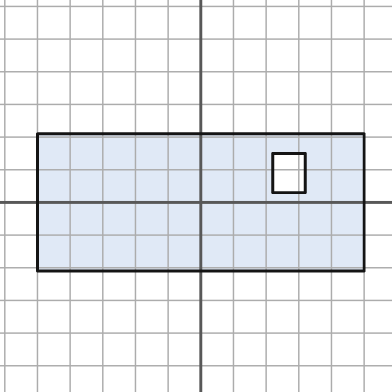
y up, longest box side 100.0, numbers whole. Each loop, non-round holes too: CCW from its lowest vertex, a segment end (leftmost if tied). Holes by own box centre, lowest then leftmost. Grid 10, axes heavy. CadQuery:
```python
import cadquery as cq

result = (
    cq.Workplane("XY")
    .moveTo(-50.0, -21.0)
    .lineTo(50.0, -21.0)
    .lineTo(50.0, 21.0)
    .lineTo(-50.0, 21.0)
    .close()
    .moveTo(22.0, 3.0)
    .lineTo(32.0, 3.0)
    .lineTo(32.0, 15.0)
    .lineTo(22.0, 15.0)
    .close()
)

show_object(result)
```